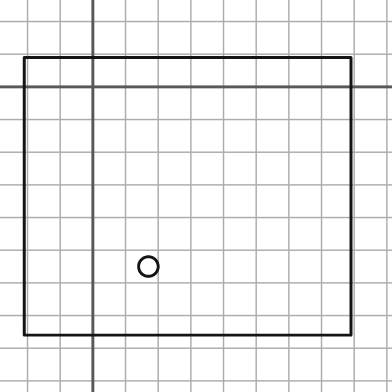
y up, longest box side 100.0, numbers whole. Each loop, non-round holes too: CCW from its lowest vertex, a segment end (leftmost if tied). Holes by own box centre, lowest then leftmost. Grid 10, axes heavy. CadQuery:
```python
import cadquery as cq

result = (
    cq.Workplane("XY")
    .moveTo(-21.0, -76.0)
    .lineTo(79.0, -76.0)
    .lineTo(79.0, 9.0)
    .lineTo(-21.0, 9.0)
    .close()
    .moveTo(17.0, -55.0)
    .circle(3.0)
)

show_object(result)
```